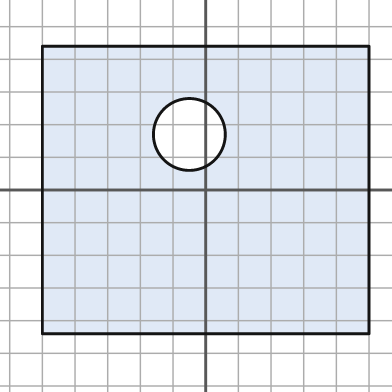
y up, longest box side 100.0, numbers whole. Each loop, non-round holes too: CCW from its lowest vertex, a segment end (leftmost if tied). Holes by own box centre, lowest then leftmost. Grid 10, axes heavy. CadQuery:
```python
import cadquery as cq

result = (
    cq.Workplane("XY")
    .moveTo(-50.0, -44.0)
    .lineTo(50.0, -44.0)
    .lineTo(50.0, 44.0)
    .lineTo(-50.0, 44.0)
    .close()
    .moveTo(-5.0, 17.0)
    .circle(11.0)
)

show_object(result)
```